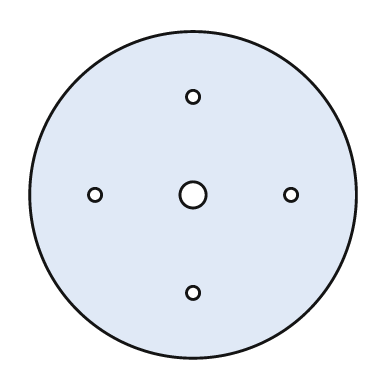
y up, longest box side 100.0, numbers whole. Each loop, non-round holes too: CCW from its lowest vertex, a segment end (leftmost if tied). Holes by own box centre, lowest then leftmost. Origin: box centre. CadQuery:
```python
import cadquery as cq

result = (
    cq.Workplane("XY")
    .moveTo(0.0, 0.0)
    .circle(50.0)
    .moveTo(0.0, -30.0)
    .circle(2.0)
    .moveTo(-30.0, 0.0)
    .circle(2.0)
    .moveTo(0.0, 0.0)
    .circle(4.0)
    .moveTo(30.0, 0.0)
    .circle(2.0)
    .moveTo(0.0, 30.0)
    .circle(2.0)
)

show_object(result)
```